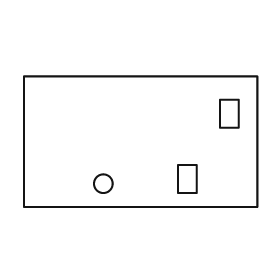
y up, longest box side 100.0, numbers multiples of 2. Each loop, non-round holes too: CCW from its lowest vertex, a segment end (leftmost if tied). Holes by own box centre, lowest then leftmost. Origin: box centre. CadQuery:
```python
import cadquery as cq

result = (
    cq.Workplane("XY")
    .moveTo(-50.0, -28.0)
    .lineTo(50.0, -28.0)
    .lineTo(50.0, 28.0)
    .lineTo(-50.0, 28.0)
    .close()
    .moveTo(-16.0, -18.0)
    .circle(4.0)
    .moveTo(16.0, -22.0)
    .lineTo(24.0, -22.0)
    .lineTo(24.0, -10.0)
    .lineTo(16.0, -10.0)
    .close()
    .moveTo(34.0, 6.0)
    .lineTo(42.0, 6.0)
    .lineTo(42.0, 18.0)
    .lineTo(34.0, 18.0)
    .close()
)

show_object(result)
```